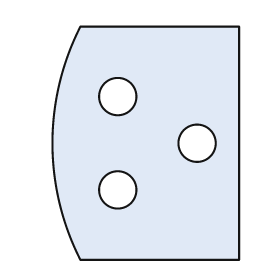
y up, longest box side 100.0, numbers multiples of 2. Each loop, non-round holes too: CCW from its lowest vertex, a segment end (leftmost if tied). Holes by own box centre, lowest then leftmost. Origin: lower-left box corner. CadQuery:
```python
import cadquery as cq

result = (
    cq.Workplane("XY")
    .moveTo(12.0, 0.0)
    .lineTo(80.0, 0.0)
    .lineTo(80.0, 100.0)
    .lineTo(12.0, 100.0)
    .threePointArc((0.0, 50.0), (12.0, 0.0))
    .close()
    .moveTo(28.0, 30.0)
    .circle(8.0)
    .moveTo(62.0, 50.0)
    .circle(8.0)
    .moveTo(28.0, 70.0)
    .circle(8.0)
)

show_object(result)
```